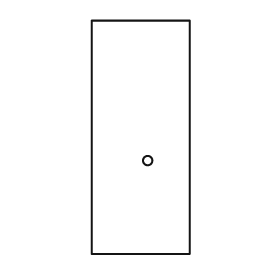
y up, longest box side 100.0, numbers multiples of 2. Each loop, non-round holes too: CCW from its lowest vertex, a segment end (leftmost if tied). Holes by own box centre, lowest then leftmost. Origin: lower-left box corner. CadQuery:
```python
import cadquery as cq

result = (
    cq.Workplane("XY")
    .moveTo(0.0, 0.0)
    .lineTo(42.0, 0.0)
    .lineTo(42.0, 100.0)
    .lineTo(0.0, 100.0)
    .close()
    .moveTo(24.0, 40.0)
    .circle(2.0)
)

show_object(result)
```